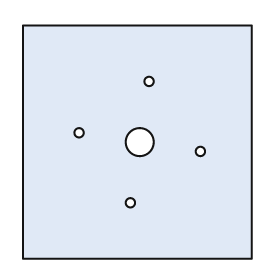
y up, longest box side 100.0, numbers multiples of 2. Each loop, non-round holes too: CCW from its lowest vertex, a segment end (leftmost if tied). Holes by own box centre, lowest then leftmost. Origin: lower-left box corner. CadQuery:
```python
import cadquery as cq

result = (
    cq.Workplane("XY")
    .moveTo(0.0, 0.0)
    .lineTo(98.0, 0.0)
    .lineTo(98.0, 100.0)
    .lineTo(0.0, 100.0)
    .close()
    .moveTo(46.0, 24.0)
    .circle(2.0)
    .moveTo(76.0, 46.0)
    .circle(2.0)
    .moveTo(50.0, 50.0)
    .circle(6.0)
    .moveTo(24.0, 54.0)
    .circle(2.0)
    .moveTo(54.0, 76.0)
    .circle(2.0)
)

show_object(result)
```